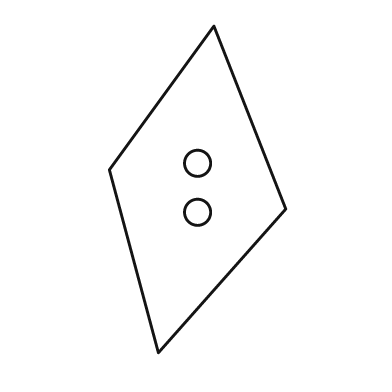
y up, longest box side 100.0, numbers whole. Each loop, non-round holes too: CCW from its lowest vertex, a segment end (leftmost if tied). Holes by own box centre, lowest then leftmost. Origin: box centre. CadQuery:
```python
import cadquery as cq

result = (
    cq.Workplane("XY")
    .moveTo(-12.0, -50.0)
    .lineTo(27.0, -6.0)
    .lineTo(5.0, 50.0)
    .lineTo(-27.0, 6.0)
    .close()
    .moveTo(0.0, -7.0)
    .circle(4.0)
    .moveTo(0.0, 8.0)
    .circle(4.0)
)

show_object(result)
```